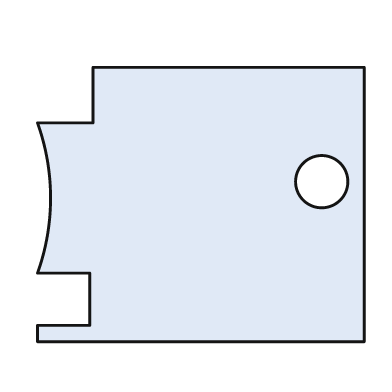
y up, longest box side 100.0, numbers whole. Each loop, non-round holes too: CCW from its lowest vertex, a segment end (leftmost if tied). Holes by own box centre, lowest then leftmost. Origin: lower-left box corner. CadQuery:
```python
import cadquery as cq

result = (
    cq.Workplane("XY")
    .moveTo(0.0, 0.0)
    .lineTo(100.0, 0.0)
    .lineTo(100.0, 84.0)
    .lineTo(17.0, 84.0)
    .lineTo(17.0, 67.0)
    .lineTo(0.0, 67.0)
    .threePointArc((4.0, 44.0), (0.0, 21.0))
    .lineTo(16.0, 21.0)
    .lineTo(16.0, 5.0)
    .lineTo(0.0, 5.0)
    .close()
    .moveTo(87.0, 49.0)
    .circle(8.0)
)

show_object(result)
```